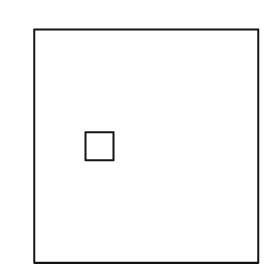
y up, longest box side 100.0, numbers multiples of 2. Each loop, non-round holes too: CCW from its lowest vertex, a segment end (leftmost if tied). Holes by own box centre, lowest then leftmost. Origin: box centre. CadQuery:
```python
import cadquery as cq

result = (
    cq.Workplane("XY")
    .moveTo(-48.0, -50.0)
    .lineTo(48.0, -50.0)
    .lineTo(48.0, 50.0)
    .lineTo(-48.0, 50.0)
    .close()
    .moveTo(-26.0, -6.0)
    .lineTo(-14.0, -6.0)
    .lineTo(-14.0, 6.0)
    .lineTo(-26.0, 6.0)
    .close()
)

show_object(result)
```